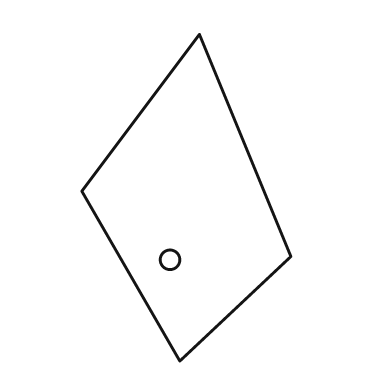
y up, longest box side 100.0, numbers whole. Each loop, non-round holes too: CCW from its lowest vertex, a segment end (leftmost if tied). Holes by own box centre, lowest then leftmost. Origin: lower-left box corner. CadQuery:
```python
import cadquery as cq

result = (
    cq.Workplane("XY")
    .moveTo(30.0, 0.0)
    .lineTo(64.0, 32.0)
    .lineTo(36.0, 100.0)
    .lineTo(0.0, 52.0)
    .close()
    .moveTo(27.0, 31.0)
    .circle(3.0)
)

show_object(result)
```